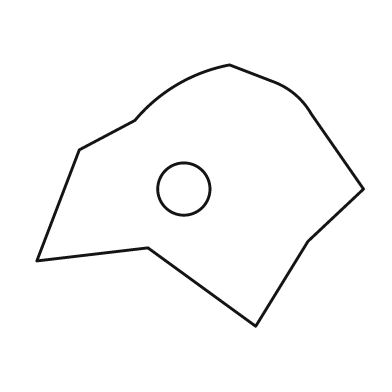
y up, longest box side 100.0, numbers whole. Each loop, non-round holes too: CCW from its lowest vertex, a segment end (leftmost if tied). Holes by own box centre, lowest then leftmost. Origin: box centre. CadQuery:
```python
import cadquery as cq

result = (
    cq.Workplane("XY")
    .moveTo(17.0, -40.0)
    .lineTo(33.0, -14.0)
    .lineTo(50.0, 2.0)
    .lineTo(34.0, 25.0)
    .threePointArc((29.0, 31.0), (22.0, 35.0))
    .lineTo(9.0, 40.0)
    .threePointArc((-7.0, 34.0), (-20.0, 23.0))
    .lineTo(-37.0, 14.0)
    .lineTo(-50.0, -20.0)
    .lineTo(-16.0, -16.0)
    .close()
    .moveTo(-5.0, 2.0)
    .circle(8.0)
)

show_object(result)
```